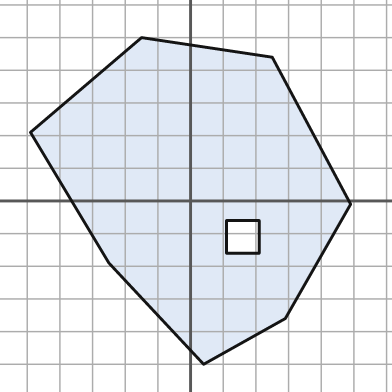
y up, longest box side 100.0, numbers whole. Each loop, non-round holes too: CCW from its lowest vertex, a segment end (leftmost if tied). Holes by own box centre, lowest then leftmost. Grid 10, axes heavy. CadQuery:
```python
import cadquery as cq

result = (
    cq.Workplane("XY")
    .moveTo(4.0, -50.0)
    .lineTo(29.0, -36.0)
    .lineTo(49.0, -1.0)
    .lineTo(25.0, 44.0)
    .lineTo(-15.0, 50.0)
    .lineTo(-49.0, 21.0)
    .lineTo(-25.0, -19.0)
    .close()
    .moveTo(11.0, -16.0)
    .lineTo(21.0, -16.0)
    .lineTo(21.0, -6.0)
    .lineTo(11.0, -6.0)
    .close()
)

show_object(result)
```